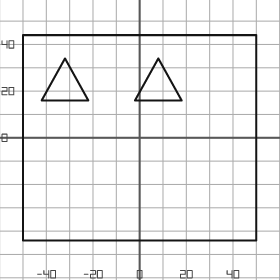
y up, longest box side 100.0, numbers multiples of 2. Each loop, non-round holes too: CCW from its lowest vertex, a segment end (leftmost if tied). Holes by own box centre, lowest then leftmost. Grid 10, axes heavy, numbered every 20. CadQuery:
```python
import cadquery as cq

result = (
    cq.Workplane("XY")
    .moveTo(-50.0, -44.0)
    .lineTo(50.0, -44.0)
    .lineTo(50.0, 44.0)
    .lineTo(-50.0, 44.0)
    .close()
    .moveTo(-42.0, 16.0)
    .lineTo(-22.0, 16.0)
    .lineTo(-32.0, 34.0)
    .close()
    .moveTo(-2.0, 16.0)
    .lineTo(18.0, 16.0)
    .lineTo(8.0, 34.0)
    .close()
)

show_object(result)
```